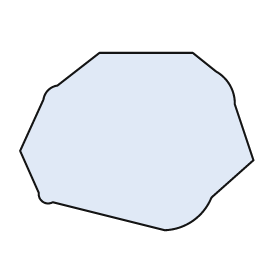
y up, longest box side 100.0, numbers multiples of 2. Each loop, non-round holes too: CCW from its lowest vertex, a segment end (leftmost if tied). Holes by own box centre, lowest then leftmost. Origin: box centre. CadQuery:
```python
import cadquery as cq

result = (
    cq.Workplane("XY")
    .moveTo(12.0, -38.0)
    .threePointArc((24.0, -34.0), (32.0, -24.0))
    .lineTo(50.0, -8.0)
    .lineTo(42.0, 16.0)
    .threePointArc((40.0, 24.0), (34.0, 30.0))
    .lineTo(24.0, 38.0)
    .lineTo(-16.0, 38.0)
    .lineTo(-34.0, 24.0)
    .threePointArc((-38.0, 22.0), (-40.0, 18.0))
    .lineTo(-50.0, -4.0)
    .lineTo(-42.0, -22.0)
    .threePointArc((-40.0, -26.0), (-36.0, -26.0))
    .close()
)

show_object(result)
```